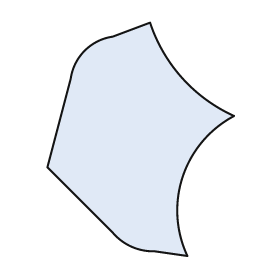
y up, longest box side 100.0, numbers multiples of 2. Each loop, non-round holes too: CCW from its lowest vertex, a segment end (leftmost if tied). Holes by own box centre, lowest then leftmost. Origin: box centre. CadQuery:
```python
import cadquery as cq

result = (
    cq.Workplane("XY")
    .moveTo(20.0, -50.0)
    .threePointArc((18.0, -16.0), (40.0, 10.0))
    .threePointArc((18.0, 26.0), (4.0, 50.0))
    .lineTo(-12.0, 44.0)
    .threePointArc((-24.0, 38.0), (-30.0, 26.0))
    .lineTo(-40.0, -12.0)
    .lineTo(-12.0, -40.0)
    .threePointArc((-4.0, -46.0), (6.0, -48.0))
    .close()
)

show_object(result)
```